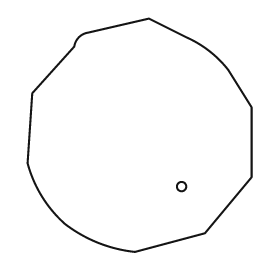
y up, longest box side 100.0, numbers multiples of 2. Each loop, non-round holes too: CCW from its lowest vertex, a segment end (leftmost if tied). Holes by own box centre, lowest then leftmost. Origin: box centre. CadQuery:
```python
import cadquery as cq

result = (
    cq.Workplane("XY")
    .moveTo(-2.0, -50.0)
    .lineTo(28.0, -42.0)
    .lineTo(48.0, -18.0)
    .lineTo(48.0, 12.0)
    .lineTo(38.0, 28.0)
    .threePointArc((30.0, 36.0), (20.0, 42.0))
    .lineTo(4.0, 50.0)
    .lineTo(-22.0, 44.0)
    .threePointArc((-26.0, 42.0), (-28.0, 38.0))
    .lineTo(-46.0, 18.0)
    .lineTo(-48.0, -12.0)
    .threePointArc((-42.0, -26.0), (-32.0, -38.0))
    .threePointArc((-18.0, -46.0), (-2.0, -50.0))
    .close()
    .moveTo(18.0, -22.0)
    .circle(2.0)
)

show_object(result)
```